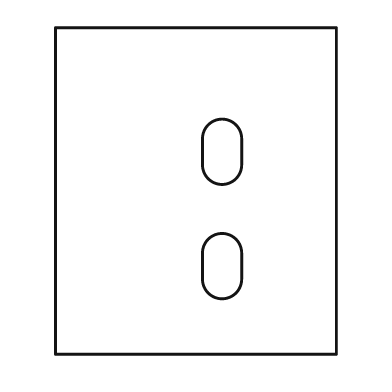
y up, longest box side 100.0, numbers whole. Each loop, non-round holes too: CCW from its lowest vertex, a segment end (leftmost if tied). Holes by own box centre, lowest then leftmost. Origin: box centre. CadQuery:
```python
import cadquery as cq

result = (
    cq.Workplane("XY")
    .moveTo(-43.0, -50.0)
    .lineTo(43.0, -50.0)
    .lineTo(43.0, 50.0)
    .lineTo(-43.0, 50.0)
    .close()
    .moveTo(2.0, -27.0)
    .threePointArc((8.0, -33.0), (14.0, -27.0))
    .lineTo(14.0, -19.0)
    .threePointArc((8.0, -13.0), (2.0, -19.0))
    .close()
    .moveTo(2.0, 8.0)
    .threePointArc((8.0, 2.0), (14.0, 8.0))
    .lineTo(14.0, 16.0)
    .threePointArc((8.0, 22.0), (2.0, 16.0))
    .close()
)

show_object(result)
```